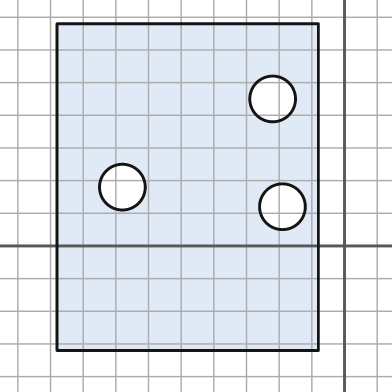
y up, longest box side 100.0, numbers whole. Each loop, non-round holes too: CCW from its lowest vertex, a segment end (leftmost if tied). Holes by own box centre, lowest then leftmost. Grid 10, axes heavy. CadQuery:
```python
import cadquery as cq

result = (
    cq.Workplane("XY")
    .moveTo(-88.0, -32.0)
    .lineTo(-8.0, -32.0)
    .lineTo(-8.0, 68.0)
    .lineTo(-88.0, 68.0)
    .close()
    .moveTo(-19.0, 12.0)
    .circle(7.0)
    .moveTo(-68.0, 18.0)
    .circle(7.0)
    .moveTo(-22.0, 45.0)
    .circle(7.0)
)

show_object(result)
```